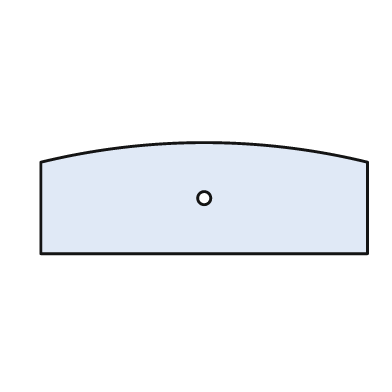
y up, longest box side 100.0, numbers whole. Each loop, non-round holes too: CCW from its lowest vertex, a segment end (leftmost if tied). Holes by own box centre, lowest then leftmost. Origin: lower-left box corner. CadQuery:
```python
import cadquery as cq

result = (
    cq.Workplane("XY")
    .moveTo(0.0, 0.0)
    .lineTo(100.0, 0.0)
    .lineTo(100.0, 28.0)
    .threePointArc((50.0, 34.0), (0.0, 28.0))
    .close()
    .moveTo(50.0, 17.0)
    .circle(2.0)
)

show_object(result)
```